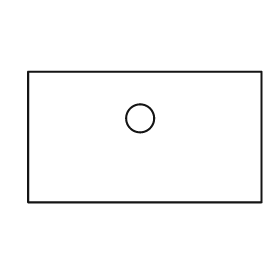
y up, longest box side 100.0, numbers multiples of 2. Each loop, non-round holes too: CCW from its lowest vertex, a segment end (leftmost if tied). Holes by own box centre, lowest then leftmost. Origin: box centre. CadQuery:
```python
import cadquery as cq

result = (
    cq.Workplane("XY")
    .moveTo(-50.0, -28.0)
    .lineTo(50.0, -28.0)
    .lineTo(50.0, 28.0)
    .lineTo(-50.0, 28.0)
    .close()
    .moveTo(-2.0, 8.0)
    .circle(6.0)
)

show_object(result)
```